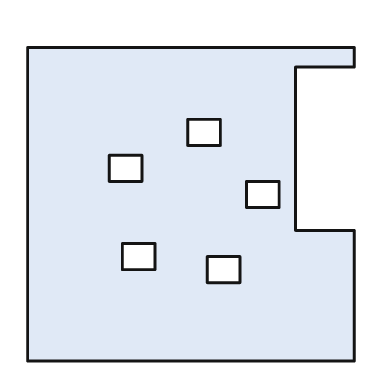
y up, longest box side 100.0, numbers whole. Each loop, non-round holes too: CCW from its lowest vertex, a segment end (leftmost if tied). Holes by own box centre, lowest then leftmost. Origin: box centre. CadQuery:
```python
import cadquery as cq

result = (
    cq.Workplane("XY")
    .moveTo(-50.0, -48.0)
    .lineTo(50.0, -48.0)
    .lineTo(50.0, -8.0)
    .lineTo(32.0, -8.0)
    .lineTo(32.0, 42.0)
    .lineTo(50.0, 42.0)
    .lineTo(50.0, 48.0)
    .lineTo(-50.0, 48.0)
    .close()
    .moveTo(5.0, -24.0)
    .lineTo(15.0, -24.0)
    .lineTo(15.0, -16.0)
    .lineTo(5.0, -16.0)
    .close()
    .moveTo(-21.0, -20.0)
    .lineTo(-11.0, -20.0)
    .lineTo(-11.0, -12.0)
    .lineTo(-21.0, -12.0)
    .close()
    .moveTo(17.0, -1.0)
    .lineTo(27.0, -1.0)
    .lineTo(27.0, 7.0)
    .lineTo(17.0, 7.0)
    .close()
    .moveTo(-25.0, 7.0)
    .lineTo(-15.0, 7.0)
    .lineTo(-15.0, 15.0)
    .lineTo(-25.0, 15.0)
    .close()
    .moveTo(-1.0, 18.0)
    .lineTo(9.0, 18.0)
    .lineTo(9.0, 26.0)
    .lineTo(-1.0, 26.0)
    .close()
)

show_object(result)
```